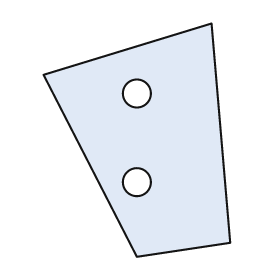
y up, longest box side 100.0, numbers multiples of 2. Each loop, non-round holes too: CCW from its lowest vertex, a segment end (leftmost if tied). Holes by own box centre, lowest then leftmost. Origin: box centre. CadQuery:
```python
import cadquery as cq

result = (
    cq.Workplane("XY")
    .moveTo(0.0, -50.0)
    .lineTo(40.0, -44.0)
    .lineTo(32.0, 50.0)
    .lineTo(-40.0, 28.0)
    .close()
    .moveTo(0.0, -18.0)
    .circle(6.0)
    .moveTo(0.0, 20.0)
    .circle(6.0)
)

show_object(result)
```